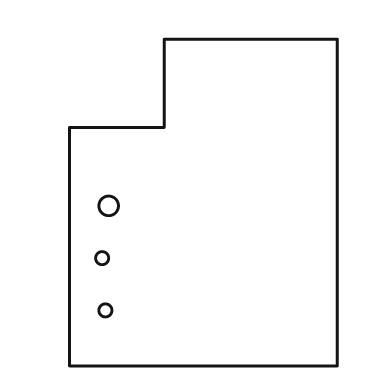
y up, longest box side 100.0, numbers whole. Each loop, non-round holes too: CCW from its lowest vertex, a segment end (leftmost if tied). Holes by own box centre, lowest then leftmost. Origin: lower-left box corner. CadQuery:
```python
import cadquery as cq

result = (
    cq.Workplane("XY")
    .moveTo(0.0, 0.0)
    .lineTo(82.0, 0.0)
    .lineTo(82.0, 100.0)
    .lineTo(29.0, 100.0)
    .lineTo(29.0, 73.0)
    .lineTo(0.0, 73.0)
    .close()
    .moveTo(11.0, 17.0)
    .circle(2.0)
    .moveTo(10.0, 33.0)
    .circle(2.0)
    .moveTo(12.0, 49.0)
    .circle(3.0)
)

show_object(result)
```